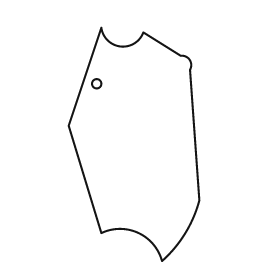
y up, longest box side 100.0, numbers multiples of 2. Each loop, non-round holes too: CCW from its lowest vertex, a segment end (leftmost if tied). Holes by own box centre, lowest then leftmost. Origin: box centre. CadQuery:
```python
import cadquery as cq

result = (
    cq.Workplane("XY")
    .moveTo(12.0, -50.0)
    .threePointArc((22.0, -38.0), (28.0, -24.0))
    .lineTo(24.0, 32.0)
    .threePointArc((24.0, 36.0), (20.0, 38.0))
    .lineTo(4.0, 48.0)
    .threePointArc((-6.0, 42.0), (-14.0, 50.0))
    .lineTo(-28.0, 8.0)
    .lineTo(-14.0, -38.0)
    .threePointArc((2.0, -38.0), (12.0, -50.0))
    .close()
    .moveTo(-16.0, 26.0)
    .circle(2.0)
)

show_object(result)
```